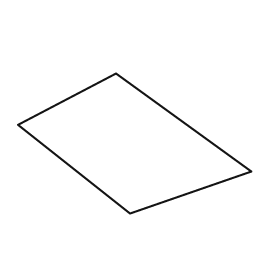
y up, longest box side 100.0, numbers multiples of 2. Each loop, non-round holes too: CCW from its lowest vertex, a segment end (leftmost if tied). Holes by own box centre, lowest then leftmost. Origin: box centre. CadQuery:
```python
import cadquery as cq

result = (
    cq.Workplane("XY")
    .moveTo(-2.0, -30.0)
    .lineTo(50.0, -12.0)
    .lineTo(-8.0, 30.0)
    .lineTo(-50.0, 8.0)
    .close()
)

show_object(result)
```